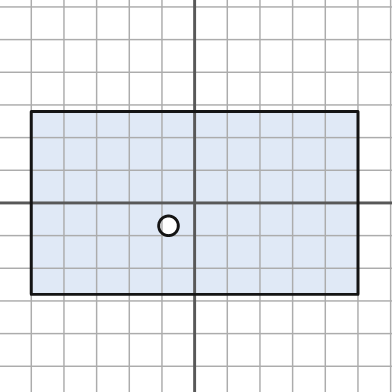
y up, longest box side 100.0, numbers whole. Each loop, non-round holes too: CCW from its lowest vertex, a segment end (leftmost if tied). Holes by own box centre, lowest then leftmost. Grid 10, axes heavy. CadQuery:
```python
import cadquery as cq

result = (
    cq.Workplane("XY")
    .moveTo(-50.0, -28.0)
    .lineTo(50.0, -28.0)
    .lineTo(50.0, 28.0)
    .lineTo(-50.0, 28.0)
    .close()
    .moveTo(-8.0, -7.0)
    .circle(3.0)
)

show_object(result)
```